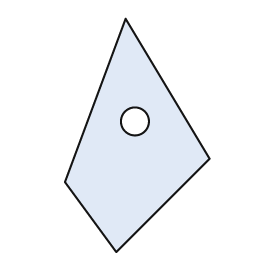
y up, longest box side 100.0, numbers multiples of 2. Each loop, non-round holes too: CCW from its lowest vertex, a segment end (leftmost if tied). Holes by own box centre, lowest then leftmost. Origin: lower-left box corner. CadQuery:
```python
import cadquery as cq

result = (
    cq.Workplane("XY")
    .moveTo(22.0, 0.0)
    .lineTo(62.0, 40.0)
    .lineTo(26.0, 100.0)
    .lineTo(0.0, 30.0)
    .close()
    .moveTo(30.0, 56.0)
    .circle(6.0)
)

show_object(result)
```